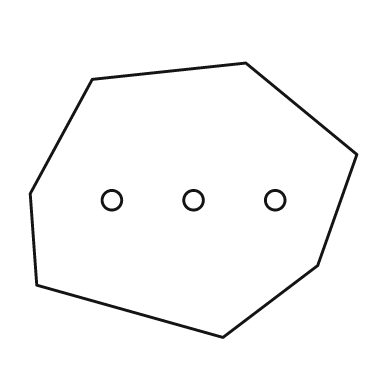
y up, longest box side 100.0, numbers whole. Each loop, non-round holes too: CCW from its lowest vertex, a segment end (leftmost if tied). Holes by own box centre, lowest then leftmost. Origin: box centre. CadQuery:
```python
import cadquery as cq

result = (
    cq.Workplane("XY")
    .moveTo(9.0, -42.0)
    .lineTo(38.0, -20.0)
    .lineTo(50.0, 14.0)
    .lineTo(16.0, 42.0)
    .lineTo(-31.0, 37.0)
    .lineTo(-50.0, 2.0)
    .lineTo(-48.0, -26.0)
    .close()
    .moveTo(-25.0, 0.0)
    .circle(3.0)
    .moveTo(0.0, 0.0)
    .circle(3.0)
    .moveTo(25.0, 0.0)
    .circle(3.0)
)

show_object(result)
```